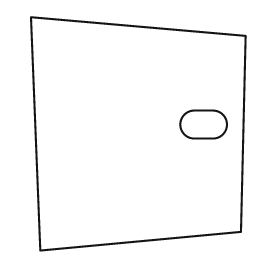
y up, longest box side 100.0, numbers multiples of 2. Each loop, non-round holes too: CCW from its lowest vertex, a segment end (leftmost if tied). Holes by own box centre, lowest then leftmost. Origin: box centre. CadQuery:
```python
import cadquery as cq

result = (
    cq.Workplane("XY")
    .moveTo(-42.0, -50.0)
    .lineTo(44.0, -42.0)
    .lineTo(46.0, 42.0)
    .lineTo(-46.0, 50.0)
    .close()
    .moveTo(24.0, -2.0)
    .lineTo(32.0, -2.0)
    .threePointArc((38.0, 4.0), (32.0, 10.0))
    .lineTo(24.0, 10.0)
    .threePointArc((18.0, 4.0), (24.0, -2.0))
    .close()
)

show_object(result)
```